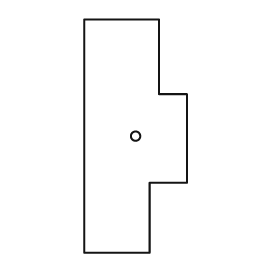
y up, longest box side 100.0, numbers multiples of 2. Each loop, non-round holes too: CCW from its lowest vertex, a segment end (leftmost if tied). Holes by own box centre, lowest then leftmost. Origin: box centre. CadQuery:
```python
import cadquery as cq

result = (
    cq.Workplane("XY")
    .moveTo(-22.0, -50.0)
    .lineTo(6.0, -50.0)
    .lineTo(6.0, -20.0)
    .lineTo(22.0, -20.0)
    .lineTo(22.0, 18.0)
    .lineTo(10.0, 18.0)
    .lineTo(10.0, 50.0)
    .lineTo(-22.0, 50.0)
    .close()
    .moveTo(0.0, 0.0)
    .circle(2.0)
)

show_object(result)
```